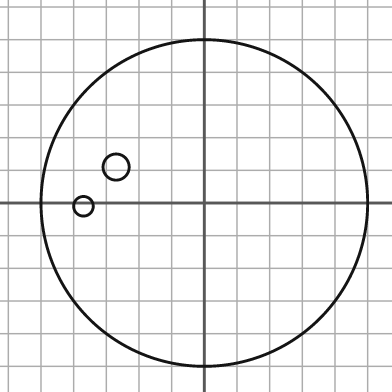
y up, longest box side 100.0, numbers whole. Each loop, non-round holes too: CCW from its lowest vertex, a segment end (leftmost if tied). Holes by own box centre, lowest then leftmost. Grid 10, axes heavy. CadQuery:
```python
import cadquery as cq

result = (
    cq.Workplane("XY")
    .moveTo(0.0, 0.0)
    .circle(50.0)
    .moveTo(-37.0, -1.0)
    .circle(3.0)
    .moveTo(-27.0, 11.0)
    .circle(4.0)
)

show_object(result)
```